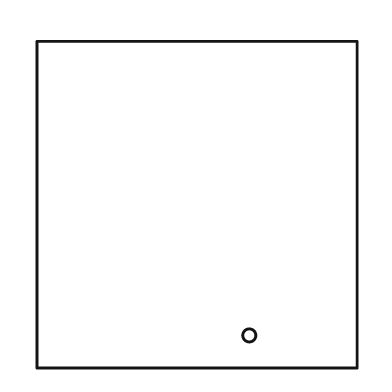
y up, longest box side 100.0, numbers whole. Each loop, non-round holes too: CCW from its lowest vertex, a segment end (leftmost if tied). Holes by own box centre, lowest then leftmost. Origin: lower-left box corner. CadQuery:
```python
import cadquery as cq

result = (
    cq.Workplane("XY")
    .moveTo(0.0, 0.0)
    .lineTo(98.0, 0.0)
    .lineTo(98.0, 100.0)
    .lineTo(0.0, 100.0)
    .close()
    .moveTo(65.0, 10.0)
    .circle(2.0)
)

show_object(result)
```